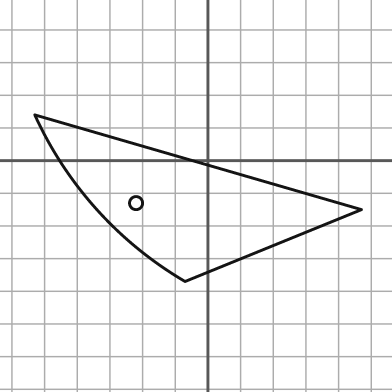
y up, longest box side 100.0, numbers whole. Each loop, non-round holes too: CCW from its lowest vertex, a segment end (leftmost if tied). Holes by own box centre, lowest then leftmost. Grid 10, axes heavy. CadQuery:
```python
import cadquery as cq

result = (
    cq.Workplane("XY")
    .moveTo(-7.0, -37.0)
    .lineTo(47.0, -15.0)
    .lineTo(-53.0, 14.0)
    .threePointArc((-34.0, -15.0), (-7.0, -37.0))
    .close()
    .moveTo(-22.0, -13.0)
    .circle(2.0)
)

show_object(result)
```